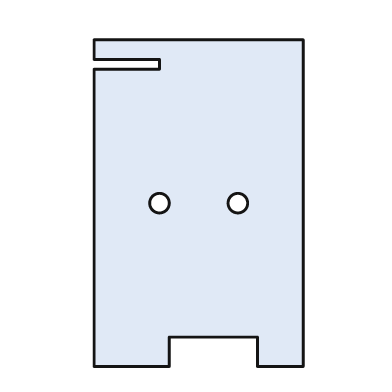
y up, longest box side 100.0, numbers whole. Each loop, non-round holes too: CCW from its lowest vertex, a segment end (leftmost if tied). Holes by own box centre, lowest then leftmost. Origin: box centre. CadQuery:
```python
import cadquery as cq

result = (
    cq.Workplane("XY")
    .moveTo(-32.0, -50.0)
    .lineTo(-9.0, -50.0)
    .lineTo(-9.0, -41.0)
    .lineTo(18.0, -41.0)
    .lineTo(18.0, -50.0)
    .lineTo(32.0, -50.0)
    .lineTo(32.0, 50.0)
    .lineTo(-32.0, 50.0)
    .lineTo(-32.0, 44.0)
    .lineTo(-12.0, 44.0)
    .lineTo(-12.0, 41.0)
    .lineTo(-32.0, 41.0)
    .close()
    .moveTo(-12.0, 0.0)
    .circle(3.0)
    .moveTo(12.0, 0.0)
    .circle(3.0)
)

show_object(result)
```